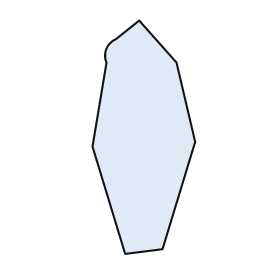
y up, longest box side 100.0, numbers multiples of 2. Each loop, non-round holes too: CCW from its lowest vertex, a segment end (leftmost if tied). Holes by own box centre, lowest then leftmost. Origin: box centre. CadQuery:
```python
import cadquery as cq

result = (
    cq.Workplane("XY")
    .moveTo(-8.0, -50.0)
    .lineTo(8.0, -48.0)
    .lineTo(22.0, -2.0)
    .lineTo(14.0, 32.0)
    .lineTo(-2.0, 50.0)
    .lineTo(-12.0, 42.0)
    .threePointArc((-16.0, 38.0), (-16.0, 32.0))
    .lineTo(-22.0, -4.0)
    .close()
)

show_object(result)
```